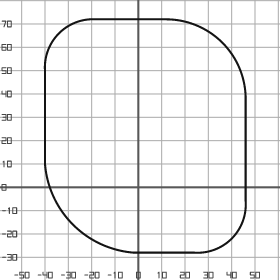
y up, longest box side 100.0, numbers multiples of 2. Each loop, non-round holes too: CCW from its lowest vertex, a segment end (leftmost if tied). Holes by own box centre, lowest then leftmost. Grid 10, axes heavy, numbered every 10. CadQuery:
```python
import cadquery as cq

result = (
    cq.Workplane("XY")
    .moveTo(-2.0, -28.0)
    .lineTo(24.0, -28.0)
    .threePointArc((40.0, -22.0), (46.0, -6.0))
    .lineTo(46.0, 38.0)
    .threePointArc((36.0, 62.0), (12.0, 72.0))
    .lineTo(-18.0, 72.0)
    .threePointArc((-34.0, 66.0), (-40.0, 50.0))
    .lineTo(-40.0, 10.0)
    .threePointArc((-28.0, -16.0), (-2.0, -28.0))
    .close()
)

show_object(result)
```